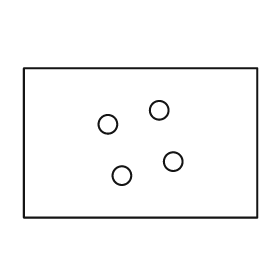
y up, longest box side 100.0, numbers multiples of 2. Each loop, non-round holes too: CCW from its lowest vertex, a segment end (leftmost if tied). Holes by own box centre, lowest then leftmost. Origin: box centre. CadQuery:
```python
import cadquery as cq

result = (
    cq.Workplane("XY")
    .moveTo(-50.0, -32.0)
    .lineTo(50.0, -32.0)
    .lineTo(50.0, 32.0)
    .lineTo(-50.0, 32.0)
    .close()
    .moveTo(-8.0, -14.0)
    .circle(4.0)
    .moveTo(14.0, -8.0)
    .circle(4.0)
    .moveTo(-14.0, 8.0)
    .circle(4.0)
    .moveTo(8.0, 14.0)
    .circle(4.0)
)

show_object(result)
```